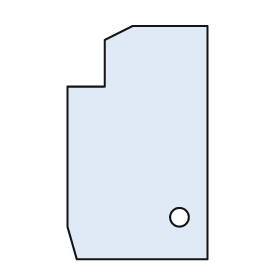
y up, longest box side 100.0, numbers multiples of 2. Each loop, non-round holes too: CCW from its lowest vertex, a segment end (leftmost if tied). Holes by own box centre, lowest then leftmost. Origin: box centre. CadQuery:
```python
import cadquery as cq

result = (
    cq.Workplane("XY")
    .moveTo(-26.0, -50.0)
    .lineTo(30.0, -50.0)
    .lineTo(30.0, 50.0)
    .lineTo(-2.0, 50.0)
    .lineTo(-14.0, 44.0)
    .lineTo(-14.0, 24.0)
    .lineTo(-30.0, 24.0)
    .lineTo(-30.0, -36.0)
    .close()
    .moveTo(18.0, -32.0)
    .circle(4.0)
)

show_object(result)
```